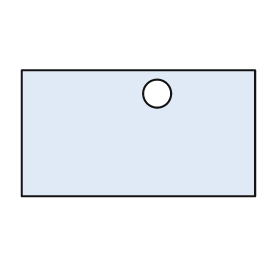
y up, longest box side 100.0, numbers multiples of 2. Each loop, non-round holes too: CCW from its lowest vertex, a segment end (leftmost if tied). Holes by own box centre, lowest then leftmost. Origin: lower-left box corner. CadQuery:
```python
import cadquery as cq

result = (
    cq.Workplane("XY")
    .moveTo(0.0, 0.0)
    .lineTo(100.0, 0.0)
    .lineTo(100.0, 54.0)
    .lineTo(0.0, 54.0)
    .close()
    .moveTo(58.0, 44.0)
    .circle(6.0)
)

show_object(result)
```